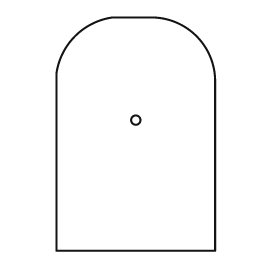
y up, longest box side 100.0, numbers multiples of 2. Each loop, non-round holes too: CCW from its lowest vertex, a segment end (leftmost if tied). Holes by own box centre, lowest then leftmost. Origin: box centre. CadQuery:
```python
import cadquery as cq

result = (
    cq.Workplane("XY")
    .moveTo(-34.0, -50.0)
    .lineTo(34.0, -50.0)
    .lineTo(34.0, 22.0)
    .threePointArc((26.0, 42.0), (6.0, 50.0))
    .lineTo(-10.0, 50.0)
    .threePointArc((-26.0, 42.0), (-34.0, 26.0))
    .close()
    .moveTo(0.0, 6.0)
    .circle(2.0)
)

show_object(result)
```